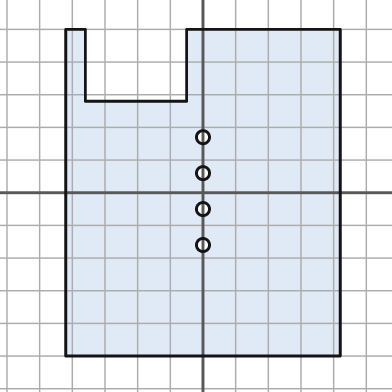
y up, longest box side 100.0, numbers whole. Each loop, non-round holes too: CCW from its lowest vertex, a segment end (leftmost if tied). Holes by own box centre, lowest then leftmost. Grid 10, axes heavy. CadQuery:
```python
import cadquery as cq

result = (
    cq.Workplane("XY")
    .moveTo(-42.0, -50.0)
    .lineTo(42.0, -50.0)
    .lineTo(42.0, 50.0)
    .lineTo(-5.0, 50.0)
    .lineTo(-5.0, 28.0)
    .lineTo(-36.0, 28.0)
    .lineTo(-36.0, 50.0)
    .lineTo(-42.0, 50.0)
    .close()
    .moveTo(0.0, -16.0)
    .circle(2.0)
    .moveTo(0.0, -5.0)
    .circle(2.0)
    .moveTo(0.0, 6.0)
    .circle(2.0)
    .moveTo(0.0, 17.0)
    .circle(2.0)
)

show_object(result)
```